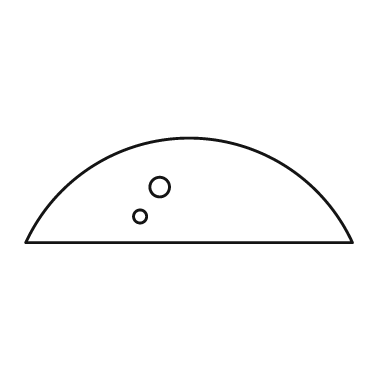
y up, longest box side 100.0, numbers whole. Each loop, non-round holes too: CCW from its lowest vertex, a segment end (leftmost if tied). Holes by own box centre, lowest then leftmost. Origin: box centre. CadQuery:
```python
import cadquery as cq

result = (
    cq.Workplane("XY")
    .moveTo(-50.0, -16.0)
    .lineTo(50.0, -16.0)
    .threePointArc((0.0, 16.0), (-50.0, -16.0))
    .close()
    .moveTo(-15.0, -8.0)
    .circle(2.0)
    .moveTo(-9.0, 1.0)
    .circle(3.0)
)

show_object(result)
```